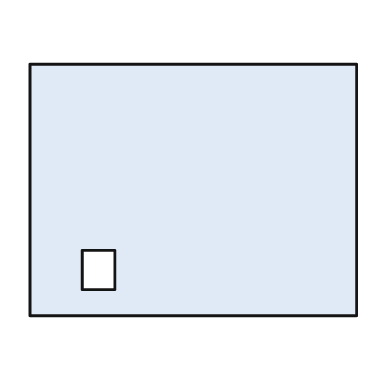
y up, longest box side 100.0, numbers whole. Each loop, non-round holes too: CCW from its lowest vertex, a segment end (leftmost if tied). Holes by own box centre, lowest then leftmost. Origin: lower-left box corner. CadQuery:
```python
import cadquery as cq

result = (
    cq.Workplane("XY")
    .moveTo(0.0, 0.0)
    .lineTo(100.0, 0.0)
    .lineTo(100.0, 77.0)
    .lineTo(0.0, 77.0)
    .close()
    .moveTo(16.0, 8.0)
    .lineTo(26.0, 8.0)
    .lineTo(26.0, 20.0)
    .lineTo(16.0, 20.0)
    .close()
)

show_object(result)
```